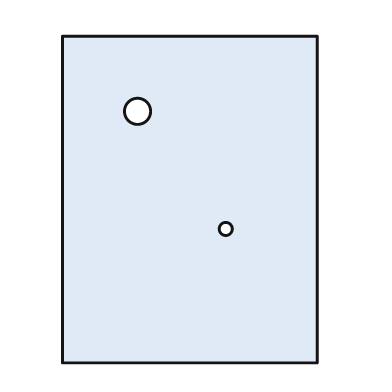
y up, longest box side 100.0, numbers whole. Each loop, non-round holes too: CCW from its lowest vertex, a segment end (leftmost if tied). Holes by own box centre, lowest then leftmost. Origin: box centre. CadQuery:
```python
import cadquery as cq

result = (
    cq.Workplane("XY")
    .moveTo(-39.0, -50.0)
    .lineTo(39.0, -50.0)
    .lineTo(39.0, 50.0)
    .lineTo(-39.0, 50.0)
    .close()
    .moveTo(11.0, -9.0)
    .circle(2.0)
    .moveTo(-16.0, 27.0)
    .circle(4.0)
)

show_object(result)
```